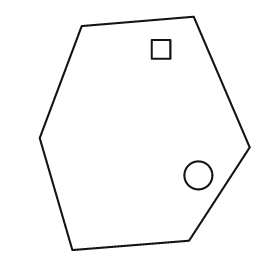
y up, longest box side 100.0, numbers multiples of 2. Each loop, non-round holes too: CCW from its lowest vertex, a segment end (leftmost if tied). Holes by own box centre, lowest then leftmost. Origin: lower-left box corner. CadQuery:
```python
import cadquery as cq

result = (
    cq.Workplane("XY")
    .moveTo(14.0, 0.0)
    .lineTo(64.0, 4.0)
    .lineTo(90.0, 44.0)
    .lineTo(66.0, 100.0)
    .lineTo(18.0, 96.0)
    .lineTo(0.0, 48.0)
    .close()
    .moveTo(68.0, 32.0)
    .circle(6.0)
    .moveTo(48.0, 82.0)
    .lineTo(56.0, 82.0)
    .lineTo(56.0, 90.0)
    .lineTo(48.0, 90.0)
    .close()
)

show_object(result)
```